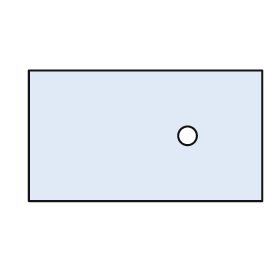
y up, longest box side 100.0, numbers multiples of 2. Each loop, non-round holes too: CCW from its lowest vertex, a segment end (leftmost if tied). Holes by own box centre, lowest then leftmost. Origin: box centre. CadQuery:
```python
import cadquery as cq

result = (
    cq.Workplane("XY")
    .moveTo(-50.0, -28.0)
    .lineTo(50.0, -28.0)
    .lineTo(50.0, 28.0)
    .lineTo(-50.0, 28.0)
    .close()
    .moveTo(18.0, 0.0)
    .circle(4.0)
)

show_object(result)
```